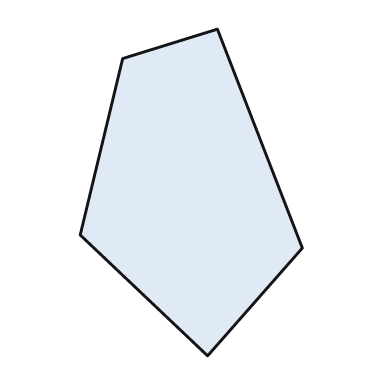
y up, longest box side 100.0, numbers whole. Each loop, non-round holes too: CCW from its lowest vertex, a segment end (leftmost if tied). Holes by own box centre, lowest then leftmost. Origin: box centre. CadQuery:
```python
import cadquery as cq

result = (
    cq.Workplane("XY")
    .moveTo(5.0, -50.0)
    .lineTo(34.0, -17.0)
    .lineTo(8.0, 50.0)
    .lineTo(-21.0, 41.0)
    .lineTo(-34.0, -13.0)
    .close()
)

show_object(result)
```